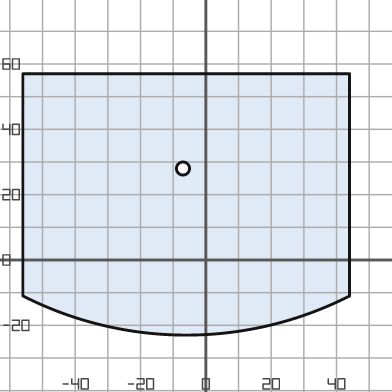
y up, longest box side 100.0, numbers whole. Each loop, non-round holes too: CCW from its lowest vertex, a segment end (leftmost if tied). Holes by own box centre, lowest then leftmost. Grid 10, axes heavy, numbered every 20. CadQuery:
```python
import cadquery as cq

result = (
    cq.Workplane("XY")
    .moveTo(-56.0, -11.0)
    .threePointArc((-6.0, -23.0), (44.0, -11.0))
    .lineTo(44.0, 57.0)
    .lineTo(-56.0, 57.0)
    .close()
    .moveTo(-7.0, 28.0)
    .circle(2.0)
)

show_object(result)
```